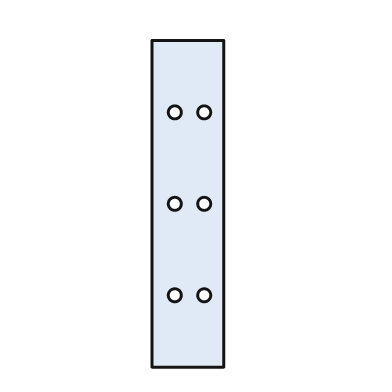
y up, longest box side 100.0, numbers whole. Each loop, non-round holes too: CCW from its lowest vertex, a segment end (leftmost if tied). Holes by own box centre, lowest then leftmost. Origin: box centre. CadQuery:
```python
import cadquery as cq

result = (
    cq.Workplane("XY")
    .moveTo(-11.0, -50.0)
    .lineTo(11.0, -50.0)
    .lineTo(11.0, 50.0)
    .lineTo(-11.0, 50.0)
    .close()
    .moveTo(-4.0, -28.0)
    .circle(2.0)
    .moveTo(5.0, -28.0)
    .circle(2.0)
    .moveTo(-4.0, 0.0)
    .circle(2.0)
    .moveTo(5.0, 0.0)
    .circle(2.0)
    .moveTo(-4.0, 28.0)
    .circle(2.0)
    .moveTo(5.0, 28.0)
    .circle(2.0)
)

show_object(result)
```